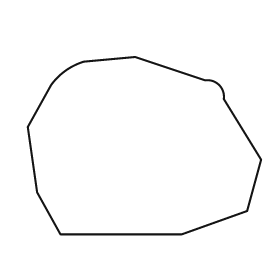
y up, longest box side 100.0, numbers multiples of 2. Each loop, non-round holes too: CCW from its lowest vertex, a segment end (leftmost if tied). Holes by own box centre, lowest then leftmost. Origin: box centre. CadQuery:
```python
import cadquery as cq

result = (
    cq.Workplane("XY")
    .moveTo(-36.0, -38.0)
    .lineTo(16.0, -38.0)
    .lineTo(44.0, -28.0)
    .lineTo(50.0, -6.0)
    .lineTo(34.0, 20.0)
    .threePointArc((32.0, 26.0), (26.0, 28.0))
    .lineTo(-4.0, 38.0)
    .lineTo(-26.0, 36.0)
    .threePointArc((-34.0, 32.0), (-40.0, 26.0))
    .lineTo(-50.0, 8.0)
    .lineTo(-46.0, -20.0)
    .close()
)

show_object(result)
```